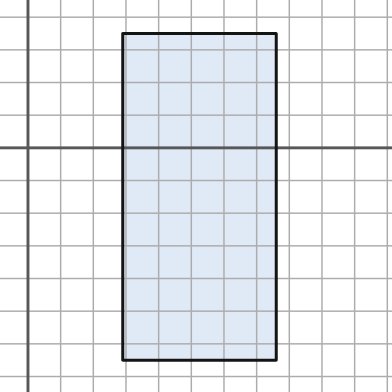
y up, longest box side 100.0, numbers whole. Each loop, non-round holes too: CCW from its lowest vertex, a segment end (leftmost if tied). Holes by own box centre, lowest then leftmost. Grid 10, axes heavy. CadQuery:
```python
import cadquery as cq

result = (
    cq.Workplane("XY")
    .moveTo(29.0, -65.0)
    .lineTo(76.0, -65.0)
    .lineTo(76.0, 35.0)
    .lineTo(29.0, 35.0)
    .close()
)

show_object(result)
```